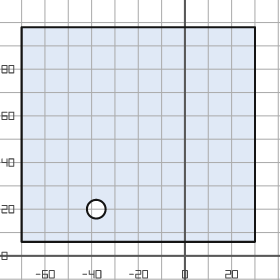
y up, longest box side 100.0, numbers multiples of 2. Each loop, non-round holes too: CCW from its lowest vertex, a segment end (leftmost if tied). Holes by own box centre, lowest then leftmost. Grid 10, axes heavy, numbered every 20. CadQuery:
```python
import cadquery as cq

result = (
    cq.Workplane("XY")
    .moveTo(-70.0, 6.0)
    .lineTo(30.0, 6.0)
    .lineTo(30.0, 98.0)
    .lineTo(-70.0, 98.0)
    .close()
    .moveTo(-38.0, 20.0)
    .circle(4.0)
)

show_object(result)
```